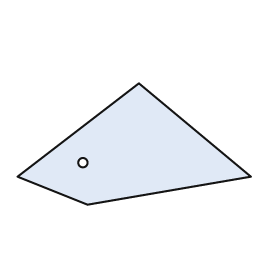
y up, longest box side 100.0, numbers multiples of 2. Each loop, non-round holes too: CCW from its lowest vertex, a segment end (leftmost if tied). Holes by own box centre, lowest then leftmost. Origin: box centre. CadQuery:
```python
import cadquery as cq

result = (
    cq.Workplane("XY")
    .moveTo(-20.0, -26.0)
    .lineTo(50.0, -14.0)
    .lineTo(2.0, 26.0)
    .lineTo(-50.0, -14.0)
    .close()
    .moveTo(-22.0, -8.0)
    .circle(2.0)
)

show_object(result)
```